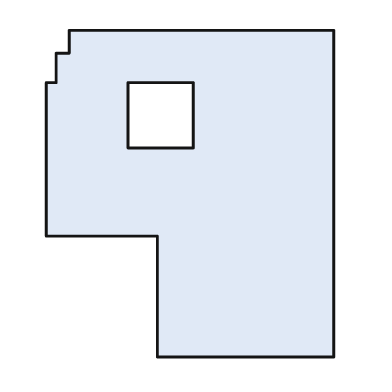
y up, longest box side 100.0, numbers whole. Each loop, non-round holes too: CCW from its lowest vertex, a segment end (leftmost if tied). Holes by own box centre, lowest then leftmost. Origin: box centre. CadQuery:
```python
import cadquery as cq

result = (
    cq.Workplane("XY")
    .moveTo(-10.0, -50.0)
    .lineTo(44.0, -50.0)
    .lineTo(44.0, 50.0)
    .lineTo(-37.0, 50.0)
    .lineTo(-37.0, 43.0)
    .lineTo(-41.0, 43.0)
    .lineTo(-41.0, 34.0)
    .lineTo(-44.0, 34.0)
    .lineTo(-44.0, -13.0)
    .lineTo(-10.0, -13.0)
    .close()
    .moveTo(-19.0, 14.0)
    .lineTo(1.0, 14.0)
    .lineTo(1.0, 34.0)
    .lineTo(-19.0, 34.0)
    .close()
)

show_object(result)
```